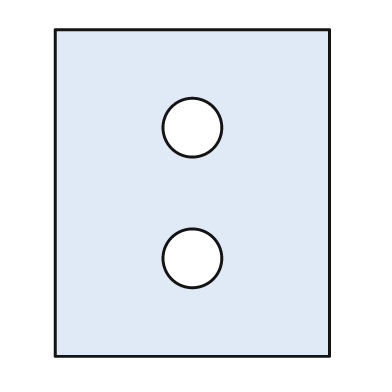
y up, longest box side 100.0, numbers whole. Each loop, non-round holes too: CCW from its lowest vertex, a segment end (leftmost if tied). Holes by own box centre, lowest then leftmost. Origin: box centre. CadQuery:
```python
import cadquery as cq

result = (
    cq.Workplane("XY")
    .moveTo(-42.0, -50.0)
    .lineTo(42.0, -50.0)
    .lineTo(42.0, 50.0)
    .lineTo(-42.0, 50.0)
    .close()
    .moveTo(0.0, -20.0)
    .circle(9.0)
    .moveTo(0.0, 20.0)
    .circle(9.0)
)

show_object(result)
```